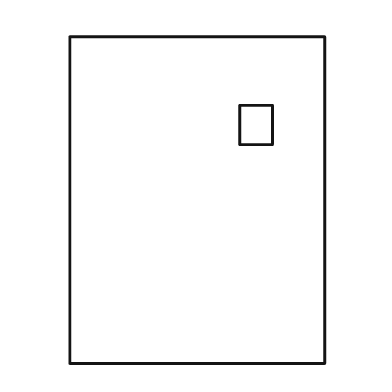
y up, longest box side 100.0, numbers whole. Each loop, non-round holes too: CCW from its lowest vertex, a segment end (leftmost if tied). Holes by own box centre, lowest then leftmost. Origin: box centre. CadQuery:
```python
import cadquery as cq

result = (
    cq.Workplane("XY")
    .moveTo(-39.0, -50.0)
    .lineTo(39.0, -50.0)
    .lineTo(39.0, 50.0)
    .lineTo(-39.0, 50.0)
    .close()
    .moveTo(13.0, 17.0)
    .lineTo(23.0, 17.0)
    .lineTo(23.0, 29.0)
    .lineTo(13.0, 29.0)
    .close()
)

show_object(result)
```